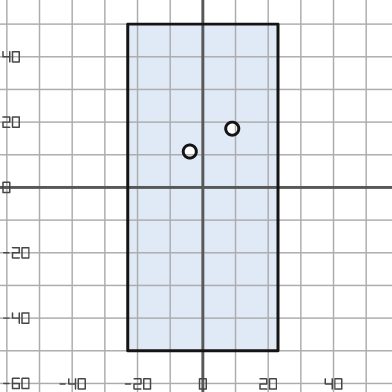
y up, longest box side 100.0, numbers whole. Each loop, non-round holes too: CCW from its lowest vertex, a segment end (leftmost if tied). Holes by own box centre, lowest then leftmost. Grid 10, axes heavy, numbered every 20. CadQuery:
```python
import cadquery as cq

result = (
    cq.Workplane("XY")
    .moveTo(-23.0, -50.0)
    .lineTo(23.0, -50.0)
    .lineTo(23.0, 50.0)
    .lineTo(-23.0, 50.0)
    .close()
    .moveTo(-4.0, 11.0)
    .circle(2.0)
    .moveTo(9.0, 18.0)
    .circle(2.0)
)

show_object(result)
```